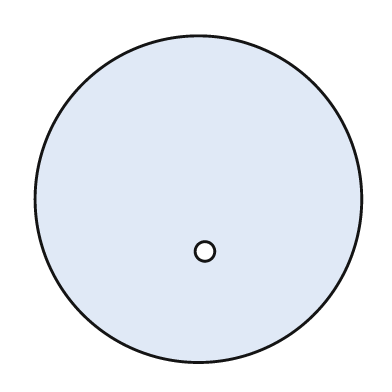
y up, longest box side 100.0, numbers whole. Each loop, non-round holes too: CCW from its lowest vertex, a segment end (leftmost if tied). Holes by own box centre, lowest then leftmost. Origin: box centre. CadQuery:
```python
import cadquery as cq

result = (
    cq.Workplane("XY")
    .moveTo(0.0, 0.0)
    .circle(50.0)
    .moveTo(2.0, -16.0)
    .circle(3.0)
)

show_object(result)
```